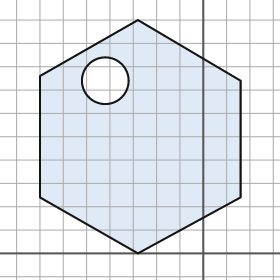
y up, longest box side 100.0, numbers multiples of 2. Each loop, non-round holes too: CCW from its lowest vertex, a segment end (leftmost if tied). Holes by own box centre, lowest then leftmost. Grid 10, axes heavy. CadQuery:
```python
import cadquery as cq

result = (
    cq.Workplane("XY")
    .moveTo(-28.0, 0.0)
    .lineTo(16.0, 24.0)
    .lineTo(16.0, 74.0)
    .lineTo(-28.0, 100.0)
    .lineTo(-70.0, 76.0)
    .lineTo(-70.0, 24.0)
    .close()
    .moveTo(-42.0, 74.0)
    .circle(10.0)
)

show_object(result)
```